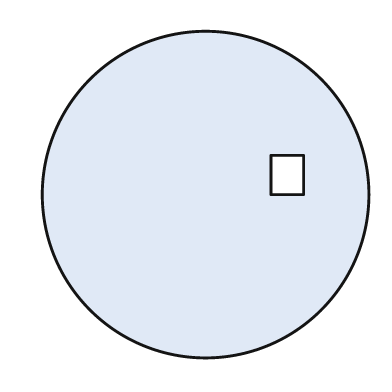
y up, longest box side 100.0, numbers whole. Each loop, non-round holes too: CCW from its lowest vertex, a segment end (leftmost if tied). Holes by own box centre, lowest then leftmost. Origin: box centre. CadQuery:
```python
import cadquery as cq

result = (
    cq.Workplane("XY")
    .moveTo(0.0, 0.0)
    .circle(50.0)
    .moveTo(20.0, 0.0)
    .lineTo(30.0, 0.0)
    .lineTo(30.0, 12.0)
    .lineTo(20.0, 12.0)
    .close()
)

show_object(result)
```